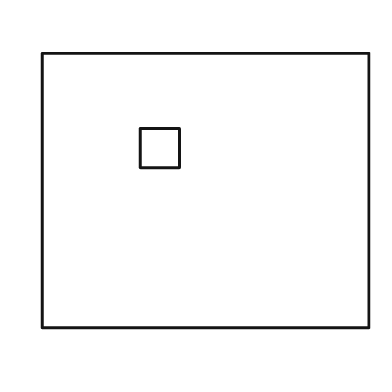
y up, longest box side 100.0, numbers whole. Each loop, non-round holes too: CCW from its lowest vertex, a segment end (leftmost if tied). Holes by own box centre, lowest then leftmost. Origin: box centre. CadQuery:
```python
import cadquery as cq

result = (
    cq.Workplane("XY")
    .moveTo(-50.0, -42.0)
    .lineTo(50.0, -42.0)
    .lineTo(50.0, 42.0)
    .lineTo(-50.0, 42.0)
    .close()
    .moveTo(-20.0, 7.0)
    .lineTo(-8.0, 7.0)
    .lineTo(-8.0, 19.0)
    .lineTo(-20.0, 19.0)
    .close()
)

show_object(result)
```